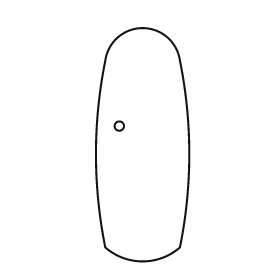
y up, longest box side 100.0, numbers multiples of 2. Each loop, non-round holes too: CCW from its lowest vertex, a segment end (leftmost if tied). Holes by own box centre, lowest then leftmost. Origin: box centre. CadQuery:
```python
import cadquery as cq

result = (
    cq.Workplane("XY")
    .moveTo(-16.0, -44.0)
    .threePointArc((0.0, -50.0), (16.0, -44.0))
    .threePointArc((20.0, -4.0), (16.0, 36.0))
    .threePointArc((0.0, 50.0), (-16.0, 36.0))
    .threePointArc((-20.0, -4.0), (-16.0, -44.0))
    .close()
    .moveTo(-10.0, 8.0)
    .circle(2.0)
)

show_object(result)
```